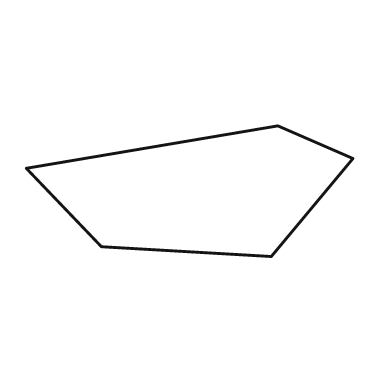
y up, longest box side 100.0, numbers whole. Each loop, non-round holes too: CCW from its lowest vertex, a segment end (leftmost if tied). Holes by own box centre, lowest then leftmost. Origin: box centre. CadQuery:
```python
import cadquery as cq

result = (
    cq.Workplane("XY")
    .moveTo(25.0, -20.0)
    .lineTo(50.0, 10.0)
    .lineTo(27.0, 20.0)
    .lineTo(-50.0, 7.0)
    .lineTo(-27.0, -17.0)
    .close()
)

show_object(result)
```